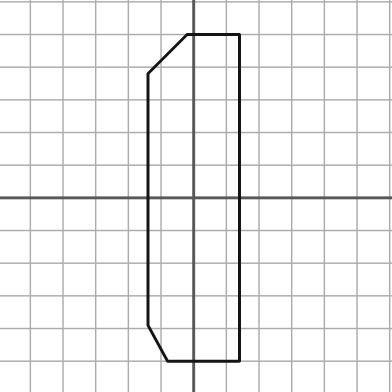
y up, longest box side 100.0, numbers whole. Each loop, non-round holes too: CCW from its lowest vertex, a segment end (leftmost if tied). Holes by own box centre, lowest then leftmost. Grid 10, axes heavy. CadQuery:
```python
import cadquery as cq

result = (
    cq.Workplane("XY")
    .moveTo(-8.0, -50.0)
    .lineTo(14.0, -50.0)
    .lineTo(14.0, 50.0)
    .lineTo(-2.0, 50.0)
    .lineTo(-14.0, 38.0)
    .lineTo(-14.0, -39.0)
    .close()
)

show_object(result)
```